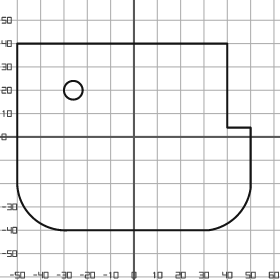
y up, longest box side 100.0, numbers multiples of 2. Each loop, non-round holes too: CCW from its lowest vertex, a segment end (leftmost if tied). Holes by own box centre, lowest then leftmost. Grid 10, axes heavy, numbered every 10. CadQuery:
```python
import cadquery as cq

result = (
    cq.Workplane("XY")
    .moveTo(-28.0, -40.0)
    .lineTo(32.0, -40.0)
    .threePointArc((44.0, -34.0), (50.0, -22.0))
    .lineTo(50.0, 4.0)
    .lineTo(40.0, 4.0)
    .lineTo(40.0, 40.0)
    .lineTo(-50.0, 40.0)
    .lineTo(-50.0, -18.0)
    .threePointArc((-44.0, -34.0), (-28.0, -40.0))
    .close()
    .moveTo(-26.0, 20.0)
    .circle(4.0)
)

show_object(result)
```